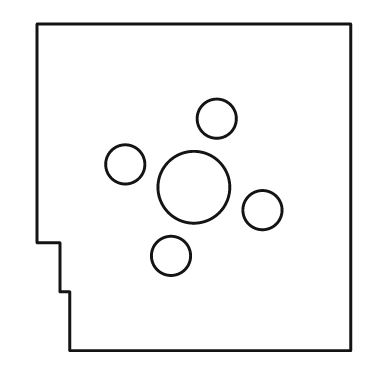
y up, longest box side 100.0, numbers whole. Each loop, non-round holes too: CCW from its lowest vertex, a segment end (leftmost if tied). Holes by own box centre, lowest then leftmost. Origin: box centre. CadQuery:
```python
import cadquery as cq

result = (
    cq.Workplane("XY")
    .moveTo(-38.0, -50.0)
    .lineTo(48.0, -50.0)
    .lineTo(48.0, 50.0)
    .lineTo(-48.0, 50.0)
    .lineTo(-48.0, -17.0)
    .lineTo(-41.0, -17.0)
    .lineTo(-41.0, -32.0)
    .lineTo(-38.0, -32.0)
    .close()
    .moveTo(-7.0, -21.0)
    .circle(6.0)
    .moveTo(21.0, -7.0)
    .circle(6.0)
    .moveTo(0.0, 0.0)
    .circle(11.0)
    .moveTo(-21.0, 7.0)
    .circle(6.0)
    .moveTo(7.0, 21.0)
    .circle(6.0)
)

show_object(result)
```